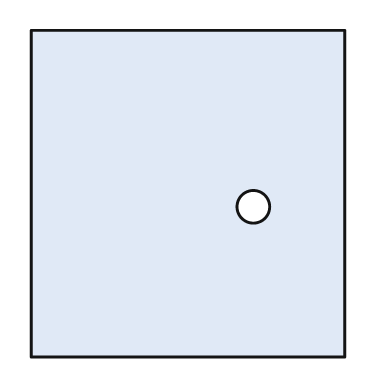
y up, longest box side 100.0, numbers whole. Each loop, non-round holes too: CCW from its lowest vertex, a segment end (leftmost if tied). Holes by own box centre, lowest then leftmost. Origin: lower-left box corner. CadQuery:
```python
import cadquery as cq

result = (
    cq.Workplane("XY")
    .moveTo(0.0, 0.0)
    .lineTo(96.0, 0.0)
    .lineTo(96.0, 100.0)
    .lineTo(0.0, 100.0)
    .close()
    .moveTo(68.0, 46.0)
    .circle(5.0)
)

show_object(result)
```